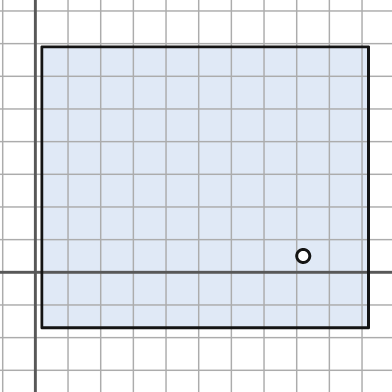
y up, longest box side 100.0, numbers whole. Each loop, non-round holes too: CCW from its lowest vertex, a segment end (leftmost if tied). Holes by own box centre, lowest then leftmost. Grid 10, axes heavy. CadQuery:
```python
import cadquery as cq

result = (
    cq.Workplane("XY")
    .moveTo(2.0, -17.0)
    .lineTo(102.0, -17.0)
    .lineTo(102.0, 69.0)
    .lineTo(2.0, 69.0)
    .close()
    .moveTo(82.0, 5.0)
    .circle(2.0)
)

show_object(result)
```